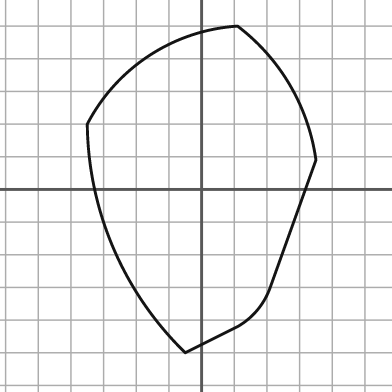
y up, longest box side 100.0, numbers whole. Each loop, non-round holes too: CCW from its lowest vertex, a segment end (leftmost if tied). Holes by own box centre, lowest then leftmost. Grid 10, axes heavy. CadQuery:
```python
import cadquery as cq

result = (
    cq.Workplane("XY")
    .moveTo(-5.0, -50.0)
    .lineTo(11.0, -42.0)
    .threePointArc((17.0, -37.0), (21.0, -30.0))
    .lineTo(35.0, 9.0)
    .threePointArc((27.0, 32.0), (11.0, 50.0))
    .threePointArc((-16.0, 41.0), (-35.0, 20.0))
    .threePointArc((-27.0, -18.0), (-5.0, -50.0))
    .close()
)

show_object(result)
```